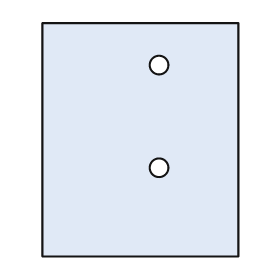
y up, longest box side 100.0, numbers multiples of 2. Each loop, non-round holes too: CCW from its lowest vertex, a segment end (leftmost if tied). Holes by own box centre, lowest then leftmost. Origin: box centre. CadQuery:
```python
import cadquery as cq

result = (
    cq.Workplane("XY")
    .moveTo(-42.0, -50.0)
    .lineTo(42.0, -50.0)
    .lineTo(42.0, 50.0)
    .lineTo(-42.0, 50.0)
    .close()
    .moveTo(8.0, -12.0)
    .circle(4.0)
    .moveTo(8.0, 32.0)
    .circle(4.0)
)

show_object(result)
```